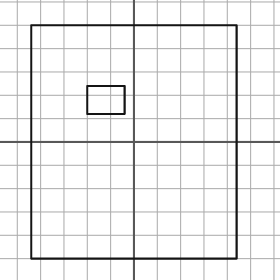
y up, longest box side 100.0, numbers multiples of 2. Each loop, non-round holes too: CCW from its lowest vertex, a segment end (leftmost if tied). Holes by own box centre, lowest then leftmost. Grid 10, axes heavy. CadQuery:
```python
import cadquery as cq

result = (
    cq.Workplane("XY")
    .moveTo(-44.0, -50.0)
    .lineTo(44.0, -50.0)
    .lineTo(44.0, 50.0)
    .lineTo(-44.0, 50.0)
    .close()
    .moveTo(-20.0, 12.0)
    .lineTo(-4.0, 12.0)
    .lineTo(-4.0, 24.0)
    .lineTo(-20.0, 24.0)
    .close()
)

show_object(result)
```